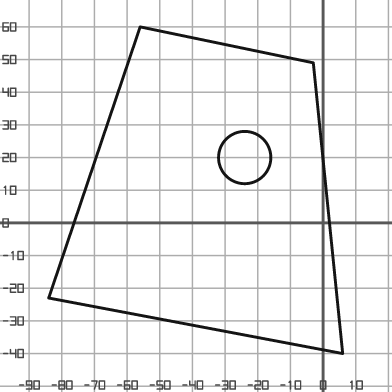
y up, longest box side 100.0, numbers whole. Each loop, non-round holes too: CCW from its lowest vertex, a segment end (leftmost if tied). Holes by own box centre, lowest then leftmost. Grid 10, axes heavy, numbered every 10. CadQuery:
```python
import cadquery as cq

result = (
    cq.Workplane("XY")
    .moveTo(6.0, -40.0)
    .lineTo(-3.0, 49.0)
    .lineTo(-56.0, 60.0)
    .lineTo(-84.0, -23.0)
    .close()
    .moveTo(-24.0, 20.0)
    .circle(8.0)
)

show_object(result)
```